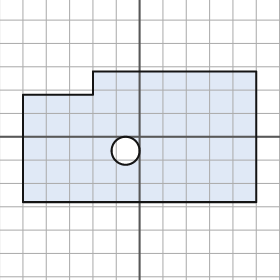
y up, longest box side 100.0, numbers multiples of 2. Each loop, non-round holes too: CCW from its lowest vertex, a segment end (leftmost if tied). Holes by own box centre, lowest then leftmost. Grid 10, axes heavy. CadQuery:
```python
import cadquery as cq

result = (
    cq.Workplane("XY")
    .moveTo(-50.0, -28.0)
    .lineTo(50.0, -28.0)
    .lineTo(50.0, 28.0)
    .lineTo(-20.0, 28.0)
    .lineTo(-20.0, 18.0)
    .lineTo(-50.0, 18.0)
    .close()
    .moveTo(-6.0, -6.0)
    .circle(6.0)
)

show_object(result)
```